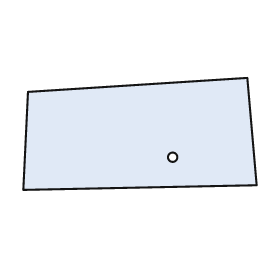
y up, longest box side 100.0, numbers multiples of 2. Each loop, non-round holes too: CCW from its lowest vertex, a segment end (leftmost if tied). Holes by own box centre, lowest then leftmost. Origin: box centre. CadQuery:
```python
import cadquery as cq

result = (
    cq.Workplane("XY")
    .moveTo(-50.0, -24.0)
    .lineTo(50.0, -22.0)
    .lineTo(46.0, 24.0)
    .lineTo(-48.0, 18.0)
    .close()
    .moveTo(14.0, -10.0)
    .circle(2.0)
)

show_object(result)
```